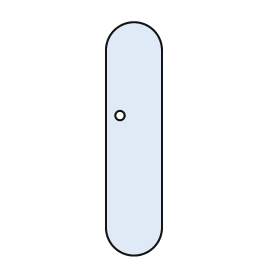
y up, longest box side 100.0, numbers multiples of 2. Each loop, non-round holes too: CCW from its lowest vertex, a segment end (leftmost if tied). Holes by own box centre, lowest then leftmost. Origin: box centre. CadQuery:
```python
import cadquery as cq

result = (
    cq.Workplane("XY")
    .moveTo(-12.0, -38.0)
    .threePointArc((0.0, -50.0), (12.0, -38.0))
    .lineTo(12.0, 38.0)
    .threePointArc((0.0, 50.0), (-12.0, 38.0))
    .close()
    .moveTo(-6.0, 10.0)
    .circle(2.0)
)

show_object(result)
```